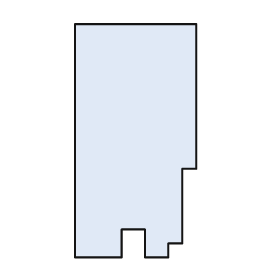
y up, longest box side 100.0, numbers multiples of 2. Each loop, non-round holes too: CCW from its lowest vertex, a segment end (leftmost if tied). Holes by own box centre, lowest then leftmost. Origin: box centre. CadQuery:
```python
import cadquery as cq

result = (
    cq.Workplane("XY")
    .moveTo(-26.0, -50.0)
    .lineTo(-6.0, -50.0)
    .lineTo(-6.0, -38.0)
    .lineTo(4.0, -38.0)
    .lineTo(4.0, -50.0)
    .lineTo(14.0, -50.0)
    .lineTo(14.0, -44.0)
    .lineTo(20.0, -44.0)
    .lineTo(20.0, -12.0)
    .lineTo(26.0, -12.0)
    .lineTo(26.0, 50.0)
    .lineTo(-26.0, 50.0)
    .close()
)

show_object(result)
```